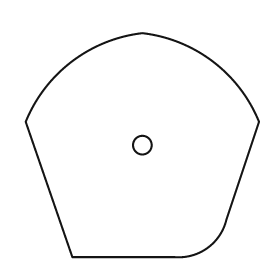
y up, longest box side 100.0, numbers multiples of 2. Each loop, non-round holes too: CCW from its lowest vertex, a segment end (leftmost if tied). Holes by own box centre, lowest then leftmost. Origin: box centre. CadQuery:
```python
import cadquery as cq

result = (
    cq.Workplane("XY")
    .moveTo(-30.0, -48.0)
    .lineTo(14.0, -48.0)
    .threePointArc((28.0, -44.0), (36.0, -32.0))
    .lineTo(50.0, 10.0)
    .threePointArc((30.0, 36.0), (0.0, 48.0))
    .threePointArc((-30.0, 36.0), (-50.0, 10.0))
    .close()
    .moveTo(0.0, 0.0)
    .circle(4.0)
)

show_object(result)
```